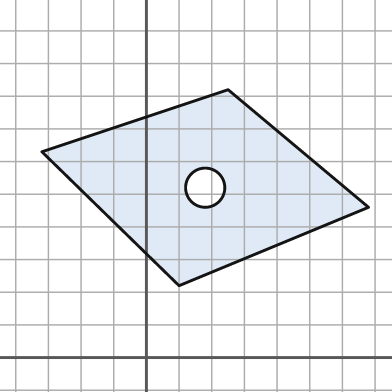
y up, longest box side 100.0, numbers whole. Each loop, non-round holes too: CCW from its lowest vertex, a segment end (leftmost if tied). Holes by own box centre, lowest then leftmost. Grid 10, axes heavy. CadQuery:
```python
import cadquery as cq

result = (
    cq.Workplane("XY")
    .moveTo(10.0, 22.0)
    .lineTo(68.0, 46.0)
    .lineTo(25.0, 82.0)
    .lineTo(-32.0, 63.0)
    .close()
    .moveTo(18.0, 52.0)
    .circle(6.0)
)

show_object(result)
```